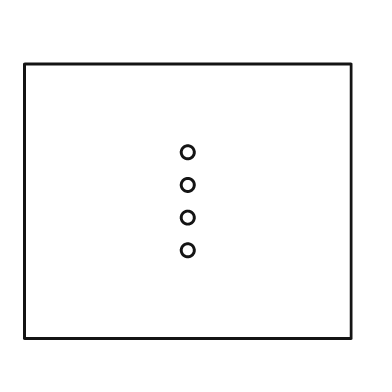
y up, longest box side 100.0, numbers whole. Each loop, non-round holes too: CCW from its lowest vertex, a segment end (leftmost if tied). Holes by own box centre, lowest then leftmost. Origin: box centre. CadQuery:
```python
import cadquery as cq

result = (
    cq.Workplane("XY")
    .moveTo(-50.0, -42.0)
    .lineTo(50.0, -42.0)
    .lineTo(50.0, 42.0)
    .lineTo(-50.0, 42.0)
    .close()
    .moveTo(0.0, -15.0)
    .circle(2.0)
    .moveTo(0.0, -5.0)
    .circle(2.0)
    .moveTo(0.0, 5.0)
    .circle(2.0)
    .moveTo(0.0, 15.0)
    .circle(2.0)
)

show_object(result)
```